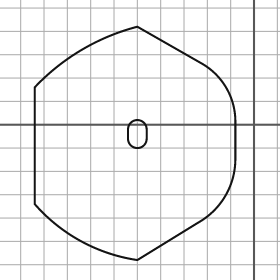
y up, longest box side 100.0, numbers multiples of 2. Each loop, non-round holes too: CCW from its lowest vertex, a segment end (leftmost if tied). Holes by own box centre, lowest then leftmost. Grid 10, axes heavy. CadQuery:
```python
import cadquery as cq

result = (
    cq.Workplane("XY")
    .moveTo(-50.0, -58.0)
    .lineTo(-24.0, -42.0)
    .threePointArc((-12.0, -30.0), (-8.0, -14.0))
    .lineTo(-8.0, 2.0)
    .threePointArc((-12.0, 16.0), (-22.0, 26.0))
    .lineTo(-50.0, 42.0)
    .threePointArc((-74.0, 32.0), (-94.0, 16.0))
    .lineTo(-94.0, -34.0)
    .threePointArc((-74.0, -50.0), (-50.0, -58.0))
    .close()
    .moveTo(-54.0, -6.0)
    .threePointArc((-50.0, -10.0), (-46.0, -6.0))
    .lineTo(-46.0, -2.0)
    .threePointArc((-50.0, 2.0), (-54.0, -2.0))
    .close()
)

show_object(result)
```